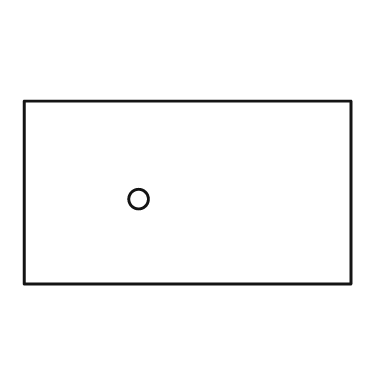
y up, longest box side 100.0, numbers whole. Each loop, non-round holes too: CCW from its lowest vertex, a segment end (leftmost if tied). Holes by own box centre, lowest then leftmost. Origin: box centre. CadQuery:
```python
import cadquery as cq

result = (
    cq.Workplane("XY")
    .moveTo(-50.0, -28.0)
    .lineTo(50.0, -28.0)
    .lineTo(50.0, 28.0)
    .lineTo(-50.0, 28.0)
    .close()
    .moveTo(-15.0, -2.0)
    .circle(3.0)
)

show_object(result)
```